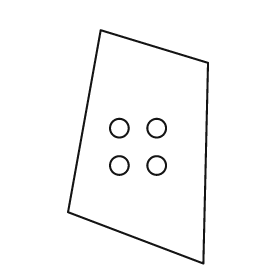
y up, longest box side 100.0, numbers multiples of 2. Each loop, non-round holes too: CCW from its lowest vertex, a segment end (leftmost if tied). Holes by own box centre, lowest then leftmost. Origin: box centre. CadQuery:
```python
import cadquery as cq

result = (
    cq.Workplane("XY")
    .moveTo(28.0, -50.0)
    .lineTo(30.0, 36.0)
    .lineTo(-16.0, 50.0)
    .lineTo(-30.0, -28.0)
    .close()
    .moveTo(-8.0, -8.0)
    .circle(4.0)
    .moveTo(8.0, -8.0)
    .circle(4.0)
    .moveTo(-8.0, 8.0)
    .circle(4.0)
    .moveTo(8.0, 8.0)
    .circle(4.0)
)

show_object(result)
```